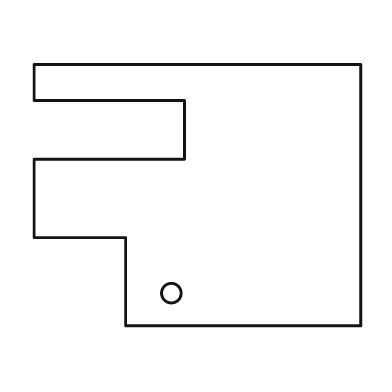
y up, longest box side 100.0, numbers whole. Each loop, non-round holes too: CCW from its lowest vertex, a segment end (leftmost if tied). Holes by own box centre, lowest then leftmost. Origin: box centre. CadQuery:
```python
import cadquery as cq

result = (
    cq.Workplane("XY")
    .moveTo(-22.0, -40.0)
    .lineTo(50.0, -40.0)
    .lineTo(50.0, 40.0)
    .lineTo(-50.0, 40.0)
    .lineTo(-50.0, 29.0)
    .lineTo(-4.0, 29.0)
    .lineTo(-4.0, 11.0)
    .lineTo(-50.0, 11.0)
    .lineTo(-50.0, -13.0)
    .lineTo(-22.0, -13.0)
    .close()
    .moveTo(-8.0, -30.0)
    .circle(3.0)
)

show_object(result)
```